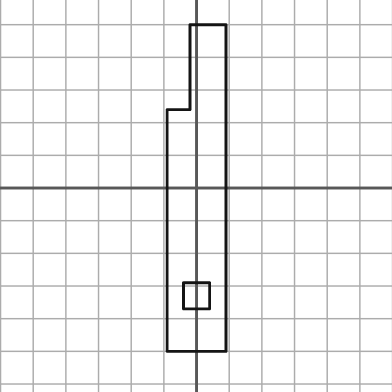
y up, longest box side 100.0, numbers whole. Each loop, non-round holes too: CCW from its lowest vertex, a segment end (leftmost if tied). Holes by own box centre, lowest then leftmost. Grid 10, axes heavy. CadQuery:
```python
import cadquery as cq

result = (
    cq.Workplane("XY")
    .moveTo(-9.0, -50.0)
    .lineTo(9.0, -50.0)
    .lineTo(9.0, 50.0)
    .lineTo(-2.0, 50.0)
    .lineTo(-2.0, 24.0)
    .lineTo(-9.0, 24.0)
    .close()
    .moveTo(-4.0, -37.0)
    .lineTo(4.0, -37.0)
    .lineTo(4.0, -29.0)
    .lineTo(-4.0, -29.0)
    .close()
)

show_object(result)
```